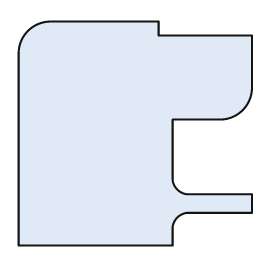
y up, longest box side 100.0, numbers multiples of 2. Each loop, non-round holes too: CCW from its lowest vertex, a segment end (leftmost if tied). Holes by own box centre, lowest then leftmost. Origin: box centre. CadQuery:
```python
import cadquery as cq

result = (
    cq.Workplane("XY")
    .moveTo(-50.0, -48.0)
    .lineTo(16.0, -48.0)
    .lineTo(16.0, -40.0)
    .threePointArc((18.0, -36.0), (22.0, -34.0))
    .lineTo(50.0, -34.0)
    .lineTo(50.0, -26.0)
    .lineTo(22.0, -26.0)
    .threePointArc((18.0, -24.0), (16.0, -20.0))
    .lineTo(16.0, 6.0)
    .lineTo(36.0, 6.0)
    .threePointArc((46.0, 10.0), (50.0, 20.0))
    .lineTo(50.0, 42.0)
    .lineTo(10.0, 42.0)
    .lineTo(10.0, 48.0)
    .lineTo(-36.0, 48.0)
    .threePointArc((-46.0, 44.0), (-50.0, 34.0))
    .close()
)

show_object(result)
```